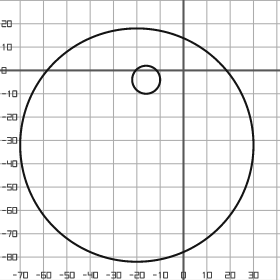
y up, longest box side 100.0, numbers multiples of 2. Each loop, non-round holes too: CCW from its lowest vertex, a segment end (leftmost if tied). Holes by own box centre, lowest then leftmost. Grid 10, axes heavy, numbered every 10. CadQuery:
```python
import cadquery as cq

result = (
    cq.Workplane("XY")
    .moveTo(-20.0, -32.0)
    .circle(50.0)
    .moveTo(-16.0, -4.0)
    .circle(6.0)
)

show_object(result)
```